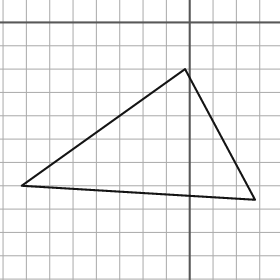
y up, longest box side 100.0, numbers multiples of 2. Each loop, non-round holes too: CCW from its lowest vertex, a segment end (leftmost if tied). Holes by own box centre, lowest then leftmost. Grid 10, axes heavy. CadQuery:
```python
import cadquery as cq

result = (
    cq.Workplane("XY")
    .moveTo(28.0, -76.0)
    .lineTo(-2.0, -20.0)
    .lineTo(-72.0, -70.0)
    .close()
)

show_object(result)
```